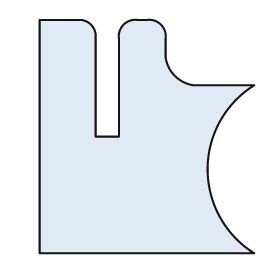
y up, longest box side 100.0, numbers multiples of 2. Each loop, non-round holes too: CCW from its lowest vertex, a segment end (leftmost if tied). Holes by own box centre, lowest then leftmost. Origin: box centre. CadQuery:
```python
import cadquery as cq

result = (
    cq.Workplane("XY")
    .moveTo(-46.0, -50.0)
    .lineTo(46.0, -50.0)
    .threePointArc((26.0, -14.0), (46.0, 22.0))
    .lineTo(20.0, 22.0)
    .threePointArc((12.0, 26.0), (8.0, 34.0))
    .lineTo(8.0, 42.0)
    .threePointArc((6.0, 48.0), (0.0, 50.0))
    .lineTo(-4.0, 50.0)
    .threePointArc((-10.0, 48.0), (-12.0, 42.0))
    .lineTo(-12.0, 0.0)
    .lineTo(-22.0, 0.0)
    .lineTo(-22.0, 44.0)
    .threePointArc((-24.0, 48.0), (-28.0, 50.0))
    .lineTo(-46.0, 50.0)
    .close()
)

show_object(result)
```